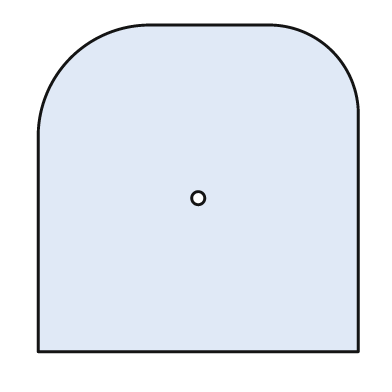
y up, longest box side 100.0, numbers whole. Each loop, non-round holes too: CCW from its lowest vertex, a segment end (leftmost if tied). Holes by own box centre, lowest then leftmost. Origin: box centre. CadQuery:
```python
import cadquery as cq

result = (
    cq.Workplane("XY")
    .moveTo(-49.0, -50.0)
    .lineTo(49.0, -50.0)
    .lineTo(49.0, 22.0)
    .threePointArc((41.0, 42.0), (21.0, 50.0))
    .lineTo(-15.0, 50.0)
    .threePointArc((-39.0, 40.0), (-49.0, 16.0))
    .close()
    .moveTo(0.0, -3.0)
    .circle(2.0)
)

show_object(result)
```